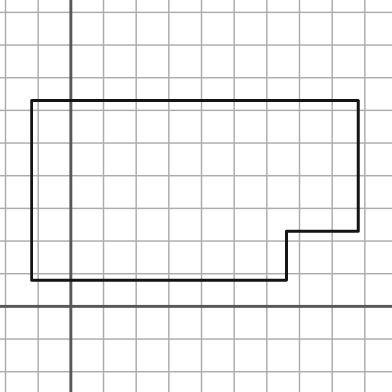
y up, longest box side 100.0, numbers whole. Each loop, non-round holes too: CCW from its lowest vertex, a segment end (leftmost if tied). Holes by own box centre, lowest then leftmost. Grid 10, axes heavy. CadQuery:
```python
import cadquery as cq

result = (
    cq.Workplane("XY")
    .moveTo(-12.0, 8.0)
    .lineTo(66.0, 8.0)
    .lineTo(66.0, 23.0)
    .lineTo(88.0, 23.0)
    .lineTo(88.0, 63.0)
    .lineTo(-12.0, 63.0)
    .close()
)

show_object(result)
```